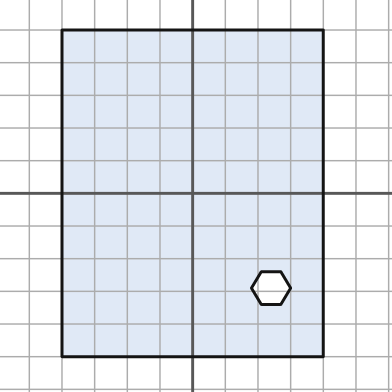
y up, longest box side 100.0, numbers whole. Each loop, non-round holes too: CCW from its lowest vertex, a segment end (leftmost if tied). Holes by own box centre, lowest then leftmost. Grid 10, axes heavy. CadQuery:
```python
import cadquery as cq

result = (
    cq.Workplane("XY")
    .moveTo(-40.0, -50.0)
    .lineTo(40.0, -50.0)
    .lineTo(40.0, 50.0)
    .lineTo(-40.0, 50.0)
    .close()
    .moveTo(21.0, -34.0)
    .lineTo(27.0, -34.0)
    .lineTo(30.0, -29.0)
    .lineTo(27.0, -24.0)
    .lineTo(21.0, -24.0)
    .lineTo(18.0, -29.0)
    .close()
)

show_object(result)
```